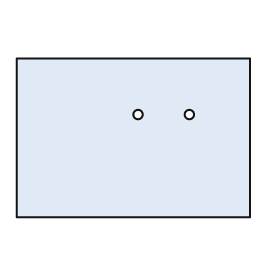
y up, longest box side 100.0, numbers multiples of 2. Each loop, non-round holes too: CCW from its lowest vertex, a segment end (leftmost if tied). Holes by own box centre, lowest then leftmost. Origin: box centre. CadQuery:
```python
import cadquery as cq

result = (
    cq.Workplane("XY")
    .moveTo(-50.0, -34.0)
    .lineTo(50.0, -34.0)
    .lineTo(50.0, 34.0)
    .lineTo(-50.0, 34.0)
    .close()
    .moveTo(2.0, 10.0)
    .circle(2.0)
    .moveTo(24.0, 10.0)
    .circle(2.0)
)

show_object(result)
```